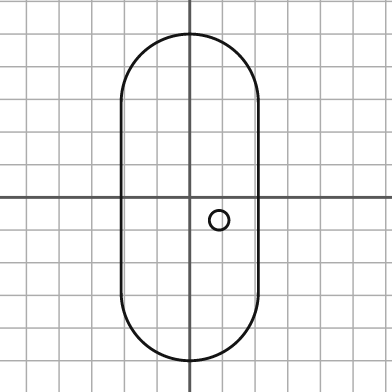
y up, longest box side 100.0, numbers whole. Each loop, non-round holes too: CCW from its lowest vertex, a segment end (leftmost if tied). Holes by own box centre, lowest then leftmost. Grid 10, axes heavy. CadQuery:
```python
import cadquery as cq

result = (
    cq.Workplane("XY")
    .moveTo(-21.0, -29.0)
    .threePointArc((0.0, -50.0), (21.0, -29.0))
    .lineTo(21.0, 29.0)
    .threePointArc((0.0, 50.0), (-21.0, 29.0))
    .close()
    .moveTo(9.0, -7.0)
    .circle(3.0)
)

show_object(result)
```